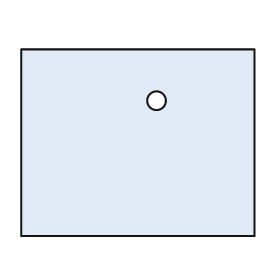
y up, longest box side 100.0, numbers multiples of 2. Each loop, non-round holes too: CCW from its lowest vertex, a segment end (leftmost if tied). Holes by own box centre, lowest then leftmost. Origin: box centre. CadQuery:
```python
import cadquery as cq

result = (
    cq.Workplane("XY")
    .moveTo(-50.0, -40.0)
    .lineTo(50.0, -40.0)
    .lineTo(50.0, 40.0)
    .lineTo(-50.0, 40.0)
    .close()
    .moveTo(8.0, 18.0)
    .circle(4.0)
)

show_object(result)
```